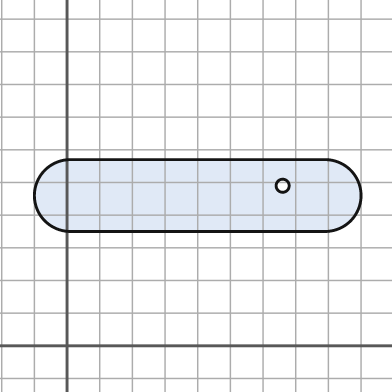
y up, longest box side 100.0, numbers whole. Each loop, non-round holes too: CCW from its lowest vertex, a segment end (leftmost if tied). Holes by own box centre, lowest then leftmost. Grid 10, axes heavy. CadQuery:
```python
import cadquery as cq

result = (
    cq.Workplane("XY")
    .moveTo(1.0, 35.0)
    .lineTo(79.0, 35.0)
    .threePointArc((90.0, 46.0), (79.0, 57.0))
    .lineTo(1.0, 57.0)
    .threePointArc((-10.0, 46.0), (1.0, 35.0))
    .close()
    .moveTo(66.0, 49.0)
    .circle(2.0)
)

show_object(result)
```